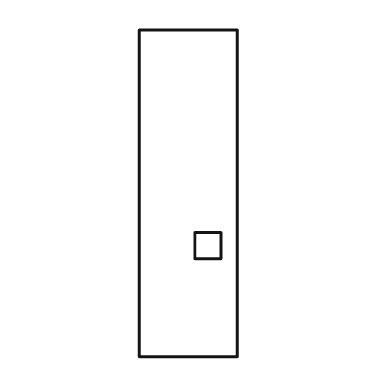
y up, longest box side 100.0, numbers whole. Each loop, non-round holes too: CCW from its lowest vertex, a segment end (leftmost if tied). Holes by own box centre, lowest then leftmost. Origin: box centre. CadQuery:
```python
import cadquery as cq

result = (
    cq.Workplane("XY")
    .moveTo(-15.0, -50.0)
    .lineTo(15.0, -50.0)
    .lineTo(15.0, 50.0)
    .lineTo(-15.0, 50.0)
    .close()
    .moveTo(2.0, -20.0)
    .lineTo(10.0, -20.0)
    .lineTo(10.0, -12.0)
    .lineTo(2.0, -12.0)
    .close()
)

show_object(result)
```